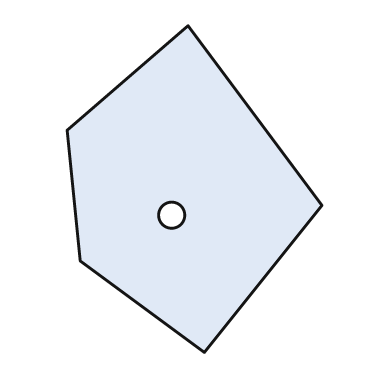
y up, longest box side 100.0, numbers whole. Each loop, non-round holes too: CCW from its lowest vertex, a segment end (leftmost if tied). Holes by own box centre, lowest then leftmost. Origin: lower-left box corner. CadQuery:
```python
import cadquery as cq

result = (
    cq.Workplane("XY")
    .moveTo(42.0, 0.0)
    .lineTo(78.0, 45.0)
    .lineTo(37.0, 100.0)
    .lineTo(0.0, 68.0)
    .lineTo(4.0, 28.0)
    .close()
    .moveTo(32.0, 42.0)
    .circle(4.0)
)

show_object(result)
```